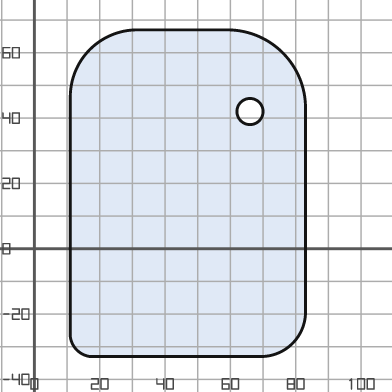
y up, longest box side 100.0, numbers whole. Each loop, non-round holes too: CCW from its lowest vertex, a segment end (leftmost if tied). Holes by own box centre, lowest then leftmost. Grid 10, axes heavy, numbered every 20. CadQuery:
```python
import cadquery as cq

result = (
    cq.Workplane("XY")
    .moveTo(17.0, -33.0)
    .lineTo(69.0, -33.0)
    .threePointArc((79.0, -29.0), (83.0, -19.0))
    .lineTo(83.0, 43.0)
    .threePointArc((76.0, 60.0), (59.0, 67.0))
    .lineTo(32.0, 67.0)
    .threePointArc((17.0, 61.0), (11.0, 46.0))
    .lineTo(11.0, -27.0)
    .threePointArc((13.0, -31.0), (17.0, -33.0))
    .close()
    .moveTo(66.0, 42.0)
    .circle(4.0)
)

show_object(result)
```